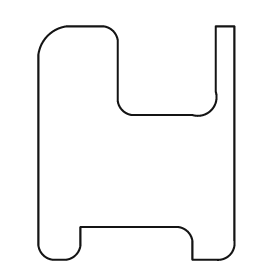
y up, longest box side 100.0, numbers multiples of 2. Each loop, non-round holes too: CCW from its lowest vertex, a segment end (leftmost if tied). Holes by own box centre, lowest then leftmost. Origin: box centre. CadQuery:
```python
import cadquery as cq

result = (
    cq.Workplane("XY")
    .moveTo(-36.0, -50.0)
    .lineTo(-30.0, -50.0)
    .threePointArc((-26.0, -48.0), (-24.0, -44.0))
    .lineTo(-24.0, -36.0)
    .lineTo(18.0, -36.0)
    .threePointArc((22.0, -38.0), (24.0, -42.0))
    .lineTo(24.0, -50.0)
    .lineTo(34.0, -50.0)
    .threePointArc((40.0, -48.0), (42.0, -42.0))
    .lineTo(42.0, 50.0)
    .lineTo(34.0, 50.0)
    .lineTo(34.0, 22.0)
    .threePointArc((32.0, 14.0), (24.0, 12.0))
    .lineTo(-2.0, 12.0)
    .threePointArc((-6.0, 14.0), (-8.0, 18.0))
    .lineTo(-8.0, 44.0)
    .threePointArc((-10.0, 48.0), (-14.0, 50.0))
    .lineTo(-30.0, 50.0)
    .threePointArc((-38.0, 46.0), (-42.0, 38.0))
    .lineTo(-42.0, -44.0)
    .threePointArc((-40.0, -48.0), (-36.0, -50.0))
    .close()
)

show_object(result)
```